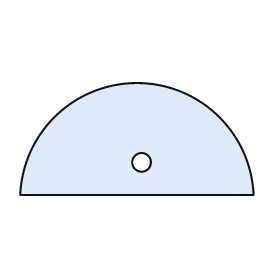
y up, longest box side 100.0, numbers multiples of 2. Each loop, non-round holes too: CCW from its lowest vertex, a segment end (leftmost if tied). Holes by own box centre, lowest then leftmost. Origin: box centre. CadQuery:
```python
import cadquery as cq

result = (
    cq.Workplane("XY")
    .moveTo(-50.0, -24.0)
    .lineTo(50.0, -24.0)
    .threePointArc((0.0, 24.0), (-50.0, -24.0))
    .close()
    .moveTo(2.0, -10.0)
    .circle(4.0)
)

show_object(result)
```